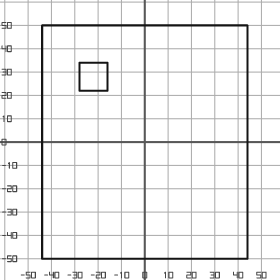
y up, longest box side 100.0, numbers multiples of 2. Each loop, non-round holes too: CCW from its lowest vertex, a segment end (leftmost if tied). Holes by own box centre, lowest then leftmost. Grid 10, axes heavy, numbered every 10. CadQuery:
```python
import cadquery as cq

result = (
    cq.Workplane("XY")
    .moveTo(-44.0, -50.0)
    .lineTo(44.0, -50.0)
    .lineTo(44.0, 50.0)
    .lineTo(-44.0, 50.0)
    .close()
    .moveTo(-28.0, 22.0)
    .lineTo(-16.0, 22.0)
    .lineTo(-16.0, 34.0)
    .lineTo(-28.0, 34.0)
    .close()
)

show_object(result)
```